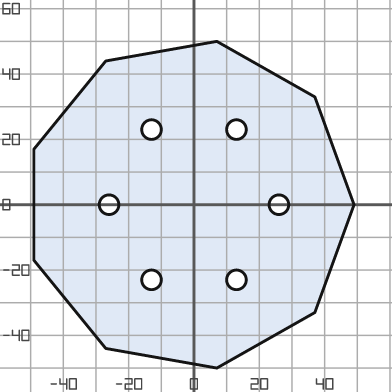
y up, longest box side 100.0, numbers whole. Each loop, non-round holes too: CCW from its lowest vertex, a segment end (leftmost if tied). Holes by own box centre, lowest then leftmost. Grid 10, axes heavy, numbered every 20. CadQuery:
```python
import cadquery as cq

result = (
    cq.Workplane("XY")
    .moveTo(7.0, -50.0)
    .lineTo(37.0, -33.0)
    .lineTo(49.0, 0.0)
    .lineTo(37.0, 33.0)
    .lineTo(7.0, 50.0)
    .lineTo(-27.0, 44.0)
    .lineTo(-49.0, 17.0)
    .lineTo(-49.0, -17.0)
    .lineTo(-27.0, -44.0)
    .close()
    .moveTo(-13.0, -23.0)
    .circle(3.0)
    .moveTo(13.0, -23.0)
    .circle(3.0)
    .moveTo(-26.0, 0.0)
    .circle(3.0)
    .moveTo(26.0, 0.0)
    .circle(3.0)
    .moveTo(-13.0, 23.0)
    .circle(3.0)
    .moveTo(13.0, 23.0)
    .circle(3.0)
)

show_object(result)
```